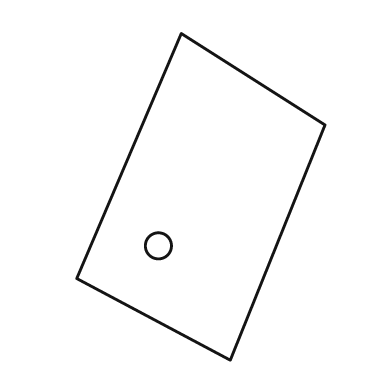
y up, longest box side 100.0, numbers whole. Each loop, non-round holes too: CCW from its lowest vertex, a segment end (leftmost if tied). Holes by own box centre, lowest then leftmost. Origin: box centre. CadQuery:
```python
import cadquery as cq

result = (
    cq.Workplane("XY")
    .moveTo(9.0, -50.0)
    .lineTo(38.0, 22.0)
    .lineTo(-6.0, 50.0)
    .lineTo(-38.0, -25.0)
    .close()
    .moveTo(-13.0, -15.0)
    .circle(4.0)
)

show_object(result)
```